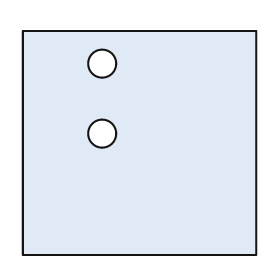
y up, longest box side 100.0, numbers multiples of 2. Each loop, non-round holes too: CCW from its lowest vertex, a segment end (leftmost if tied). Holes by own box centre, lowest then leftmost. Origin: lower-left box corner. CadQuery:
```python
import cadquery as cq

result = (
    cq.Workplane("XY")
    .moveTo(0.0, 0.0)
    .lineTo(100.0, 0.0)
    .lineTo(100.0, 96.0)
    .lineTo(0.0, 96.0)
    .close()
    .moveTo(34.0, 52.0)
    .circle(6.0)
    .moveTo(34.0, 82.0)
    .circle(6.0)
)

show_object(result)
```